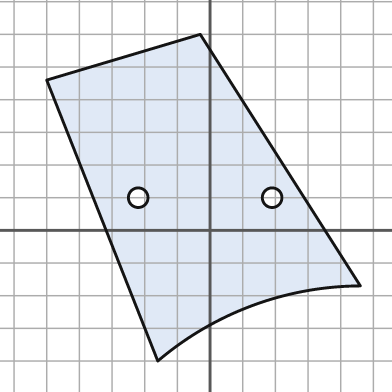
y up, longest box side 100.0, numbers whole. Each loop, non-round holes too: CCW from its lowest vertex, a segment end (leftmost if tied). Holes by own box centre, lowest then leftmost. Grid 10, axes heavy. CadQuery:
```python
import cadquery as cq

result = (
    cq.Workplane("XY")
    .moveTo(-16.0, -40.0)
    .threePointArc((13.0, -23.0), (46.0, -17.0))
    .lineTo(-3.0, 60.0)
    .lineTo(-50.0, 46.0)
    .close()
    .moveTo(-22.0, 10.0)
    .circle(3.0)
    .moveTo(19.0, 10.0)
    .circle(3.0)
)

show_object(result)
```